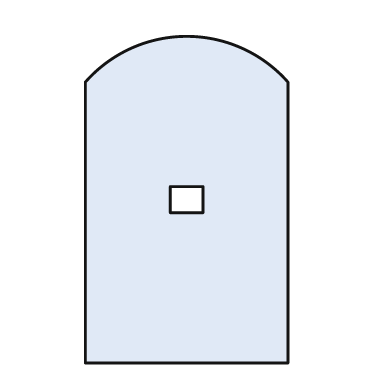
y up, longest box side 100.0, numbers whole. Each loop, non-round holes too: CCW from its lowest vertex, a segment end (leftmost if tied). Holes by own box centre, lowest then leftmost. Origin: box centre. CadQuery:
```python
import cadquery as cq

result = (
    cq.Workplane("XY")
    .moveTo(-31.0, -50.0)
    .lineTo(31.0, -50.0)
    .lineTo(31.0, 36.0)
    .threePointArc((0.0, 50.0), (-31.0, 36.0))
    .close()
    .moveTo(-5.0, -4.0)
    .lineTo(5.0, -4.0)
    .lineTo(5.0, 4.0)
    .lineTo(-5.0, 4.0)
    .close()
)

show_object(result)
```